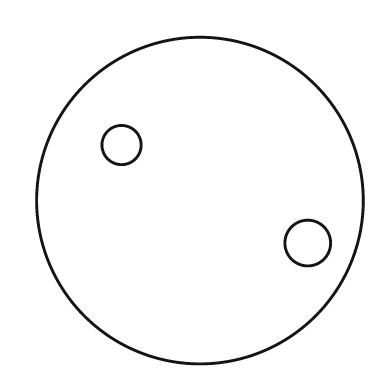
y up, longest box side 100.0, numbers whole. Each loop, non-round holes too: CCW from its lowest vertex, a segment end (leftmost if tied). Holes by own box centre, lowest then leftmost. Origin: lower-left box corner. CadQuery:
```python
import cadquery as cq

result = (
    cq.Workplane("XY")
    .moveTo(50.0, 50.0)
    .circle(50.0)
    .moveTo(83.0, 37.0)
    .circle(7.0)
    .moveTo(26.0, 67.0)
    .circle(6.0)
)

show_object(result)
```